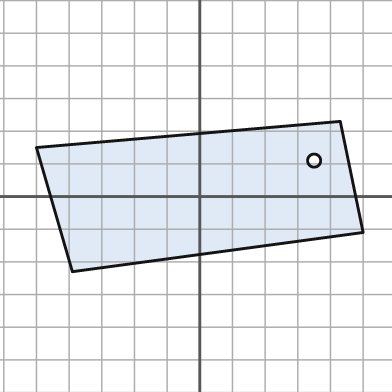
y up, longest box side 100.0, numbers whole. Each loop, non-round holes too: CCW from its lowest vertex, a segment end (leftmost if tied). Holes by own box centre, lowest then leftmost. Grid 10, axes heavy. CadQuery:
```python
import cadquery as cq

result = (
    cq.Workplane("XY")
    .moveTo(-39.0, -23.0)
    .lineTo(50.0, -11.0)
    .lineTo(43.0, 23.0)
    .lineTo(-50.0, 15.0)
    .close()
    .moveTo(35.0, 11.0)
    .circle(2.0)
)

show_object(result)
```